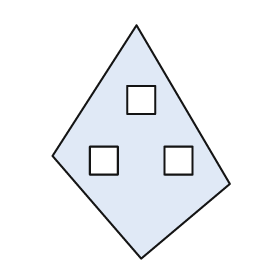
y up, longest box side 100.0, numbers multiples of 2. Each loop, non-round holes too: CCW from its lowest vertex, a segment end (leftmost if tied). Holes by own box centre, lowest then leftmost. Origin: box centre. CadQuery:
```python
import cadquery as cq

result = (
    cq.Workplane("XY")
    .moveTo(0.0, -50.0)
    .lineTo(38.0, -18.0)
    .lineTo(-2.0, 50.0)
    .lineTo(-38.0, -6.0)
    .close()
    .moveTo(-22.0, -14.0)
    .lineTo(-10.0, -14.0)
    .lineTo(-10.0, -2.0)
    .lineTo(-22.0, -2.0)
    .close()
    .moveTo(10.0, -14.0)
    .lineTo(22.0, -14.0)
    .lineTo(22.0, -2.0)
    .lineTo(10.0, -2.0)
    .close()
    .moveTo(-6.0, 12.0)
    .lineTo(6.0, 12.0)
    .lineTo(6.0, 24.0)
    .lineTo(-6.0, 24.0)
    .close()
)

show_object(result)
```